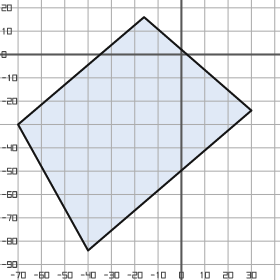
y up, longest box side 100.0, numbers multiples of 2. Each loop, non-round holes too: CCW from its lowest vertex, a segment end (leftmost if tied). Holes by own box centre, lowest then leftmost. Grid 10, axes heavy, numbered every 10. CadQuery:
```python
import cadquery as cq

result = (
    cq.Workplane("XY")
    .moveTo(-40.0, -84.0)
    .lineTo(30.0, -24.0)
    .lineTo(-16.0, 16.0)
    .lineTo(-70.0, -30.0)
    .close()
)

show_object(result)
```